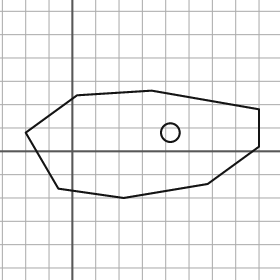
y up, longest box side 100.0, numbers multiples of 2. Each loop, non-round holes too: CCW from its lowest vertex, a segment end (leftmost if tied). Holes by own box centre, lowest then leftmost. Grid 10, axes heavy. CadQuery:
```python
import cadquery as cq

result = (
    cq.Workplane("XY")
    .moveTo(22.0, -20.0)
    .lineTo(58.0, -14.0)
    .lineTo(80.0, 2.0)
    .lineTo(80.0, 18.0)
    .lineTo(34.0, 26.0)
    .lineTo(2.0, 24.0)
    .lineTo(-20.0, 8.0)
    .lineTo(-6.0, -16.0)
    .close()
    .moveTo(42.0, 8.0)
    .circle(4.0)
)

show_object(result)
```